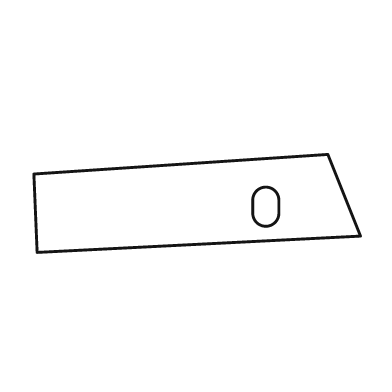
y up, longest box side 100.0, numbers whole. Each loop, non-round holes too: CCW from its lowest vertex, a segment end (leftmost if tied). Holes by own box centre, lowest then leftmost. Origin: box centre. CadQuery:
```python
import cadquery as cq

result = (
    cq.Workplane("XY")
    .moveTo(-49.0, -15.0)
    .lineTo(50.0, -10.0)
    .lineTo(40.0, 15.0)
    .lineTo(-50.0, 9.0)
    .close()
    .moveTo(17.0, -3.0)
    .threePointArc((21.0, -7.0), (25.0, -3.0))
    .lineTo(25.0, 1.0)
    .threePointArc((21.0, 5.0), (17.0, 1.0))
    .close()
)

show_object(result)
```